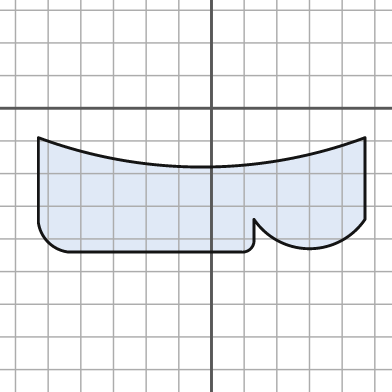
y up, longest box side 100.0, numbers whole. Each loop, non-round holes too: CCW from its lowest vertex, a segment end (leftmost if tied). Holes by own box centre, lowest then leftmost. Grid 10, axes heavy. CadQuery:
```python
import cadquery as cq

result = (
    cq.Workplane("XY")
    .moveTo(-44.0, -44.0)
    .lineTo(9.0, -44.0)
    .threePointArc((12.0, -43.0), (13.0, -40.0))
    .lineTo(13.0, -34.0)
    .threePointArc((30.0, -43.0), (47.0, -34.0))
    .lineTo(47.0, -9.0)
    .threePointArc((-3.0, -18.0), (-53.0, -9.0))
    .lineTo(-53.0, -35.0)
    .threePointArc((-50.0, -41.0), (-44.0, -44.0))
    .close()
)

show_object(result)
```